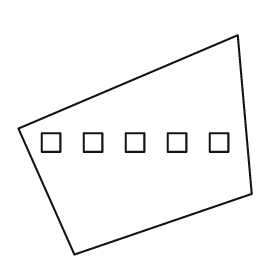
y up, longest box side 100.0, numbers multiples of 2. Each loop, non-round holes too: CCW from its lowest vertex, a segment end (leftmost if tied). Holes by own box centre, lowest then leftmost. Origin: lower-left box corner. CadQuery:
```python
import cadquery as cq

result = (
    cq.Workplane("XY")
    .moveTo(24.0, 0.0)
    .lineTo(100.0, 26.0)
    .lineTo(94.0, 94.0)
    .lineTo(0.0, 54.0)
    .close()
    .moveTo(10.0, 44.0)
    .lineTo(18.0, 44.0)
    .lineTo(18.0, 52.0)
    .lineTo(10.0, 52.0)
    .close()
    .moveTo(28.0, 44.0)
    .lineTo(36.0, 44.0)
    .lineTo(36.0, 52.0)
    .lineTo(28.0, 52.0)
    .close()
    .moveTo(46.0, 44.0)
    .lineTo(54.0, 44.0)
    .lineTo(54.0, 52.0)
    .lineTo(46.0, 52.0)
    .close()
    .moveTo(64.0, 44.0)
    .lineTo(72.0, 44.0)
    .lineTo(72.0, 52.0)
    .lineTo(64.0, 52.0)
    .close()
    .moveTo(82.0, 44.0)
    .lineTo(90.0, 44.0)
    .lineTo(90.0, 52.0)
    .lineTo(82.0, 52.0)
    .close()
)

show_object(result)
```